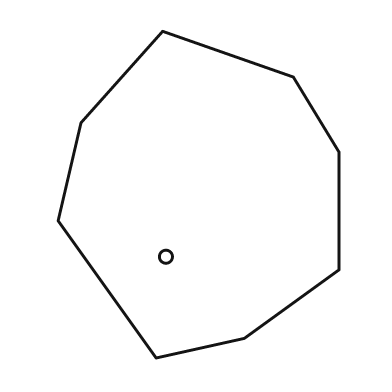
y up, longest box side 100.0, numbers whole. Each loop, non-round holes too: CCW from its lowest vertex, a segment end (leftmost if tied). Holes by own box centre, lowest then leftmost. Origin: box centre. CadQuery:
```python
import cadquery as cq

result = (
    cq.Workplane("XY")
    .moveTo(-13.0, -50.0)
    .lineTo(14.0, -44.0)
    .lineTo(43.0, -23.0)
    .lineTo(43.0, 13.0)
    .lineTo(29.0, 36.0)
    .lineTo(-11.0, 50.0)
    .lineTo(-36.0, 22.0)
    .lineTo(-43.0, -8.0)
    .close()
    .moveTo(-10.0, -19.0)
    .circle(2.0)
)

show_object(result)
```